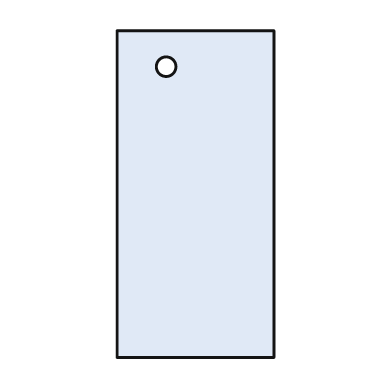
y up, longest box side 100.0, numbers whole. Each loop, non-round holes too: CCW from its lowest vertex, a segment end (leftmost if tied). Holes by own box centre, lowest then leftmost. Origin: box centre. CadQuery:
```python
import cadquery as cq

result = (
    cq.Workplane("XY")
    .moveTo(-24.0, -50.0)
    .lineTo(24.0, -50.0)
    .lineTo(24.0, 50.0)
    .lineTo(-24.0, 50.0)
    .close()
    .moveTo(-9.0, 39.0)
    .circle(3.0)
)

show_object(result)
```